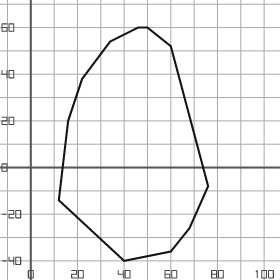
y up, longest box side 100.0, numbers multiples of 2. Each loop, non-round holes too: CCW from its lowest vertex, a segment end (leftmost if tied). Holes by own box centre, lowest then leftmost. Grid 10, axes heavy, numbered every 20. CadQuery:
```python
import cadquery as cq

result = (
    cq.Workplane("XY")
    .moveTo(40.0, -40.0)
    .lineTo(60.0, -36.0)
    .lineTo(68.0, -26.0)
    .lineTo(76.0, -8.0)
    .lineTo(60.0, 52.0)
    .lineTo(50.0, 60.0)
    .lineTo(46.0, 60.0)
    .lineTo(34.0, 54.0)
    .lineTo(22.0, 38.0)
    .lineTo(16.0, 20.0)
    .lineTo(12.0, -14.0)
    .close()
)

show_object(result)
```